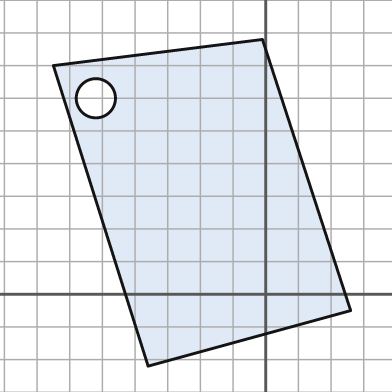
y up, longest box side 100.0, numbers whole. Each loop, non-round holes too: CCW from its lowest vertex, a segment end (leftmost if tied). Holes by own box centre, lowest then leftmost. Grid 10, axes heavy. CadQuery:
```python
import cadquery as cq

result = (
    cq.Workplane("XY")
    .moveTo(-36.0, -22.0)
    .lineTo(26.0, -5.0)
    .lineTo(-1.0, 78.0)
    .lineTo(-65.0, 70.0)
    .close()
    .moveTo(-52.0, 60.0)
    .circle(6.0)
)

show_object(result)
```